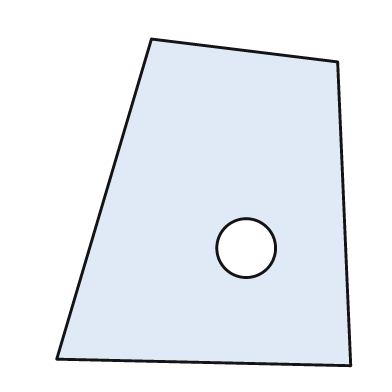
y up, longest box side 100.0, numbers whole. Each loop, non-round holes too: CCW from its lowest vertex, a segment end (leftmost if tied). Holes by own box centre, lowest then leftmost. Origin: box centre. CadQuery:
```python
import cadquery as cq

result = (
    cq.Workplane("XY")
    .moveTo(45.0, -50.0)
    .lineTo(41.0, 43.0)
    .lineTo(-16.0, 50.0)
    .lineTo(-45.0, -48.0)
    .close()
    .moveTo(13.0, -14.0)
    .circle(9.0)
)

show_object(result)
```